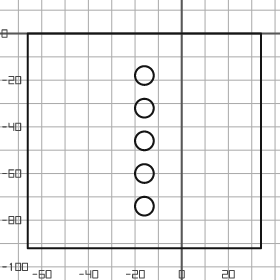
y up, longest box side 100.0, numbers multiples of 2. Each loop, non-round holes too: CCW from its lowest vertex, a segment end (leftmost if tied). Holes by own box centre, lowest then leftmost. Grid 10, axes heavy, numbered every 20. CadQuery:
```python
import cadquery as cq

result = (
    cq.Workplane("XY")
    .moveTo(-66.0, -92.0)
    .lineTo(34.0, -92.0)
    .lineTo(34.0, 0.0)
    .lineTo(-66.0, 0.0)
    .close()
    .moveTo(-16.0, -74.0)
    .circle(4.0)
    .moveTo(-16.0, -60.0)
    .circle(4.0)
    .moveTo(-16.0, -46.0)
    .circle(4.0)
    .moveTo(-16.0, -32.0)
    .circle(4.0)
    .moveTo(-16.0, -18.0)
    .circle(4.0)
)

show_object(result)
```